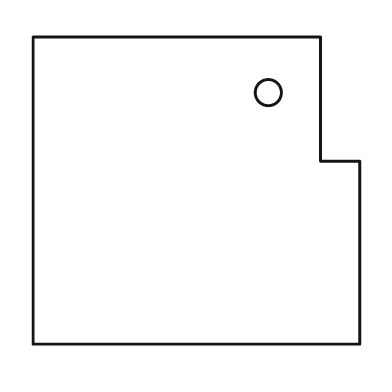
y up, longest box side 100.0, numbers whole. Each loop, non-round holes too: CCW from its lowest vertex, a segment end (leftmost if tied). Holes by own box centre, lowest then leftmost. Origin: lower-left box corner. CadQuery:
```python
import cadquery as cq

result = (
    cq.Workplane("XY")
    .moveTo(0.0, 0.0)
    .lineTo(100.0, 0.0)
    .lineTo(100.0, 56.0)
    .lineTo(88.0, 56.0)
    .lineTo(88.0, 94.0)
    .lineTo(0.0, 94.0)
    .close()
    .moveTo(72.0, 77.0)
    .circle(4.0)
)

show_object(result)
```